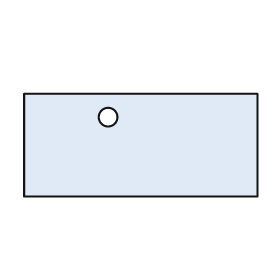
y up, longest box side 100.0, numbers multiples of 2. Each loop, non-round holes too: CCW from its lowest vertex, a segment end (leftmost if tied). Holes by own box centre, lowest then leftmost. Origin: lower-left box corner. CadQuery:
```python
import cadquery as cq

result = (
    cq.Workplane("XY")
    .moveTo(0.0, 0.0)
    .lineTo(100.0, 0.0)
    .lineTo(100.0, 44.0)
    .lineTo(0.0, 44.0)
    .close()
    .moveTo(36.0, 34.0)
    .circle(4.0)
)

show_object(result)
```